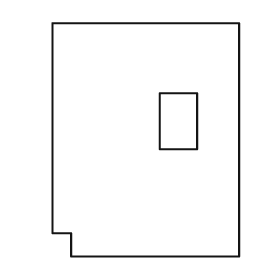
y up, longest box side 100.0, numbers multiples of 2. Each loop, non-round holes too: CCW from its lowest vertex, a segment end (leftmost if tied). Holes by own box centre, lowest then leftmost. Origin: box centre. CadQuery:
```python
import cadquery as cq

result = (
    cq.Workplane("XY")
    .moveTo(-32.0, -50.0)
    .lineTo(40.0, -50.0)
    .lineTo(40.0, 50.0)
    .lineTo(-40.0, 50.0)
    .lineTo(-40.0, -40.0)
    .lineTo(-32.0, -40.0)
    .close()
    .moveTo(6.0, -4.0)
    .lineTo(22.0, -4.0)
    .lineTo(22.0, 20.0)
    .lineTo(6.0, 20.0)
    .close()
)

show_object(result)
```